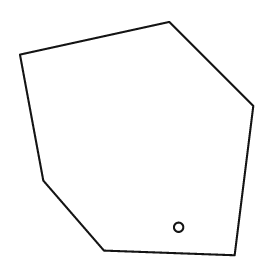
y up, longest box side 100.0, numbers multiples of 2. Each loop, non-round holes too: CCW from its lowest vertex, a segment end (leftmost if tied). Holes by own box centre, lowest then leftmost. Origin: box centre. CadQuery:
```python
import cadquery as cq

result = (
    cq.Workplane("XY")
    .moveTo(42.0, -50.0)
    .lineTo(50.0, 14.0)
    .lineTo(14.0, 50.0)
    .lineTo(-50.0, 36.0)
    .lineTo(-40.0, -18.0)
    .lineTo(-14.0, -48.0)
    .close()
    .moveTo(18.0, -38.0)
    .circle(2.0)
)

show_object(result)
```